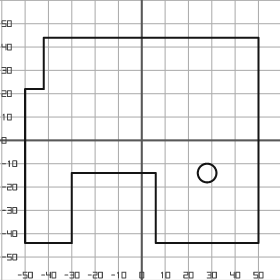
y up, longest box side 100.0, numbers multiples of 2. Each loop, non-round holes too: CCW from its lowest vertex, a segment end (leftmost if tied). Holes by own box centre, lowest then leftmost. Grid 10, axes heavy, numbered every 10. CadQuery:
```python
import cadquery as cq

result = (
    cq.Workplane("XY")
    .moveTo(-50.0, -44.0)
    .lineTo(-30.0, -44.0)
    .lineTo(-30.0, -14.0)
    .lineTo(6.0, -14.0)
    .lineTo(6.0, -44.0)
    .lineTo(50.0, -44.0)
    .lineTo(50.0, 44.0)
    .lineTo(-42.0, 44.0)
    .lineTo(-42.0, 22.0)
    .lineTo(-50.0, 22.0)
    .close()
    .moveTo(28.0, -14.0)
    .circle(4.0)
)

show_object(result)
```